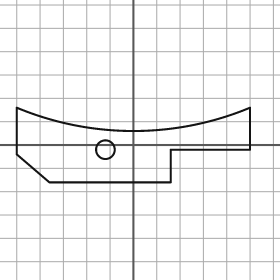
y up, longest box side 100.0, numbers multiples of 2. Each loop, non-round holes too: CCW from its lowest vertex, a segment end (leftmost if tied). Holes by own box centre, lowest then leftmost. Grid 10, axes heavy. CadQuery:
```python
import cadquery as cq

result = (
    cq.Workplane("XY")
    .moveTo(-36.0, -16.0)
    .lineTo(16.0, -16.0)
    .lineTo(16.0, -2.0)
    .lineTo(50.0, -2.0)
    .lineTo(50.0, 16.0)
    .threePointArc((0.0, 6.0), (-50.0, 16.0))
    .lineTo(-50.0, -4.0)
    .close()
    .moveTo(-12.0, -2.0)
    .circle(4.0)
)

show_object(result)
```